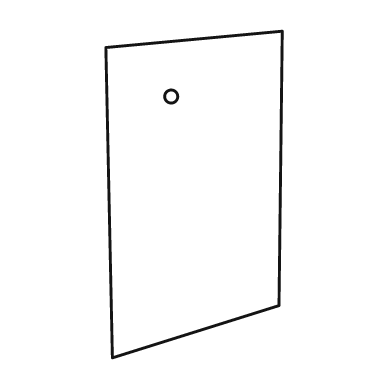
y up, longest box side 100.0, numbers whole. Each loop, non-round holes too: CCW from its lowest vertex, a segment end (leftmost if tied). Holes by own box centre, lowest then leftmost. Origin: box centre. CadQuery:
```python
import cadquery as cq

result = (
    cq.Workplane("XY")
    .moveTo(-25.0, -50.0)
    .lineTo(26.0, -34.0)
    .lineTo(27.0, 50.0)
    .lineTo(-27.0, 45.0)
    .close()
    .moveTo(-7.0, 30.0)
    .circle(2.0)
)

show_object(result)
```